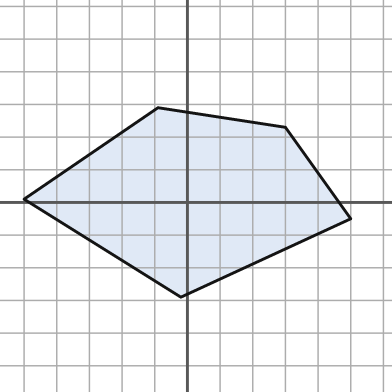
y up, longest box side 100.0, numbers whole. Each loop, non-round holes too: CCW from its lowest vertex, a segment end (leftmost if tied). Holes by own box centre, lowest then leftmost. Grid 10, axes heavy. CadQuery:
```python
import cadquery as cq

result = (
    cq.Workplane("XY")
    .moveTo(-2.0, -29.0)
    .lineTo(50.0, -5.0)
    .lineTo(30.0, 23.0)
    .lineTo(-9.0, 29.0)
    .lineTo(-50.0, 1.0)
    .close()
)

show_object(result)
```